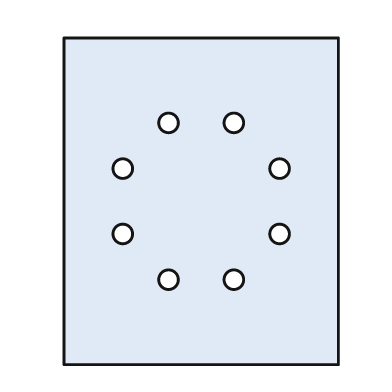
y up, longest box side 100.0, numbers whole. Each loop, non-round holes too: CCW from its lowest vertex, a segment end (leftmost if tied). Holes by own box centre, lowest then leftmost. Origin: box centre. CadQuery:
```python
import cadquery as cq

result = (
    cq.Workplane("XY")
    .moveTo(-42.0, -50.0)
    .lineTo(42.0, -50.0)
    .lineTo(42.0, 50.0)
    .lineTo(-42.0, 50.0)
    .close()
    .moveTo(-10.0, -24.0)
    .circle(3.0)
    .moveTo(10.0, -24.0)
    .circle(3.0)
    .moveTo(-24.0, -10.0)
    .circle(3.0)
    .moveTo(24.0, -10.0)
    .circle(3.0)
    .moveTo(-24.0, 10.0)
    .circle(3.0)
    .moveTo(24.0, 10.0)
    .circle(3.0)
    .moveTo(-10.0, 24.0)
    .circle(3.0)
    .moveTo(10.0, 24.0)
    .circle(3.0)
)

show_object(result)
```